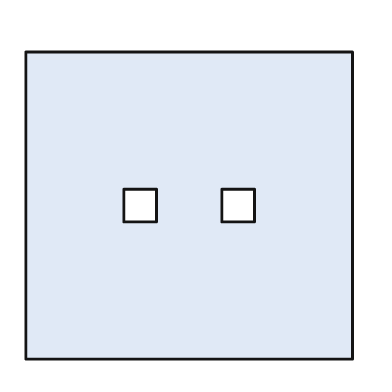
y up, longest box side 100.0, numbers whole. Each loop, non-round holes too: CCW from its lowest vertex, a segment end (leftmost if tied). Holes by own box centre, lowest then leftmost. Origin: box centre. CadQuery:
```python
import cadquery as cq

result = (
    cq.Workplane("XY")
    .moveTo(-50.0, -47.0)
    .lineTo(50.0, -47.0)
    .lineTo(50.0, 47.0)
    .lineTo(-50.0, 47.0)
    .close()
    .moveTo(-20.0, -5.0)
    .lineTo(-10.0, -5.0)
    .lineTo(-10.0, 5.0)
    .lineTo(-20.0, 5.0)
    .close()
    .moveTo(10.0, -5.0)
    .lineTo(20.0, -5.0)
    .lineTo(20.0, 5.0)
    .lineTo(10.0, 5.0)
    .close()
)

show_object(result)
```